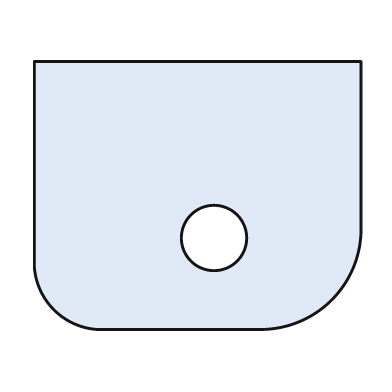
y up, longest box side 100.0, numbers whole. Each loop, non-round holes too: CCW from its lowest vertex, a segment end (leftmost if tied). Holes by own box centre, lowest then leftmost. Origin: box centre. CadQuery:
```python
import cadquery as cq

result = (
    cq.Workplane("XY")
    .moveTo(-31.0, -41.0)
    .lineTo(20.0, -41.0)
    .threePointArc((41.0, -32.0), (50.0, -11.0))
    .lineTo(50.0, 41.0)
    .lineTo(-50.0, 41.0)
    .lineTo(-50.0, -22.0)
    .threePointArc((-44.0, -35.0), (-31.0, -41.0))
    .close()
    .moveTo(5.0, -13.0)
    .circle(10.0)
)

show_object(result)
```